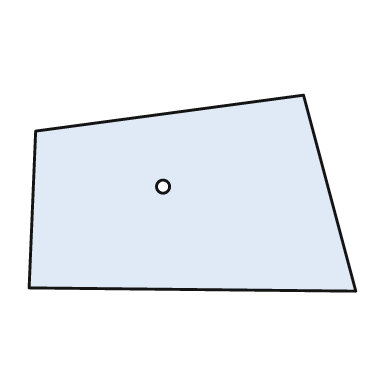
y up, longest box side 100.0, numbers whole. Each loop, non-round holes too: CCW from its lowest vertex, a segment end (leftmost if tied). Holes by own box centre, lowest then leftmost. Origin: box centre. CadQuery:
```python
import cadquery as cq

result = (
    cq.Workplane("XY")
    .moveTo(50.0, -30.0)
    .lineTo(34.0, 30.0)
    .lineTo(-48.0, 19.0)
    .lineTo(-50.0, -29.0)
    .close()
    .moveTo(-9.0, 2.0)
    .circle(2.0)
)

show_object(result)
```